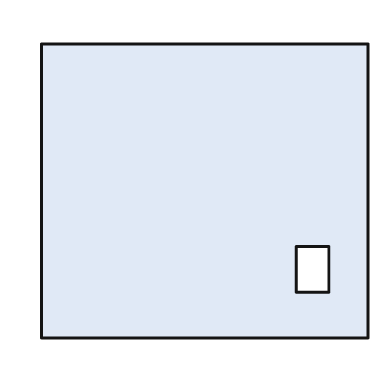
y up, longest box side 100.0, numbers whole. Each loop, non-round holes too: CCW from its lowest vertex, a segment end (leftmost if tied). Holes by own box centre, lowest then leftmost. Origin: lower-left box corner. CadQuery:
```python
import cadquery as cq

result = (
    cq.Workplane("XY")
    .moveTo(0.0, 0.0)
    .lineTo(100.0, 0.0)
    .lineTo(100.0, 90.0)
    .lineTo(0.0, 90.0)
    .close()
    .moveTo(78.0, 14.0)
    .lineTo(88.0, 14.0)
    .lineTo(88.0, 28.0)
    .lineTo(78.0, 28.0)
    .close()
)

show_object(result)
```